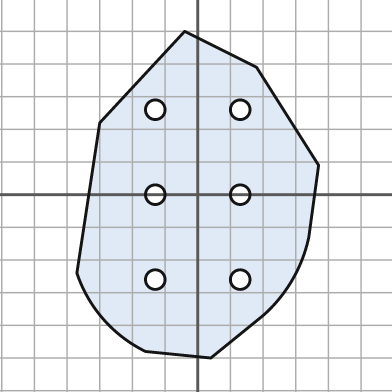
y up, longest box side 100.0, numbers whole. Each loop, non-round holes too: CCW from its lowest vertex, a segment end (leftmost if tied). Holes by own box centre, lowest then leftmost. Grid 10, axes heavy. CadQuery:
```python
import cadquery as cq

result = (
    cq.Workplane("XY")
    .moveTo(4.0, -50.0)
    .lineTo(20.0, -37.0)
    .threePointArc((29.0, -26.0), (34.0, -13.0))
    .lineTo(37.0, 9.0)
    .lineTo(18.0, 39.0)
    .lineTo(-4.0, 50.0)
    .lineTo(-30.0, 22.0)
    .lineTo(-37.0, -24.0)
    .threePointArc((-29.0, -38.0), (-16.0, -48.0))
    .close()
    .moveTo(-13.0, -26.0)
    .circle(3.0)
    .moveTo(13.0, -26.0)
    .circle(3.0)
    .moveTo(-13.0, 0.0)
    .circle(3.0)
    .moveTo(13.0, 0.0)
    .circle(3.0)
    .moveTo(-13.0, 26.0)
    .circle(3.0)
    .moveTo(13.0, 26.0)
    .circle(3.0)
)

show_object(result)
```